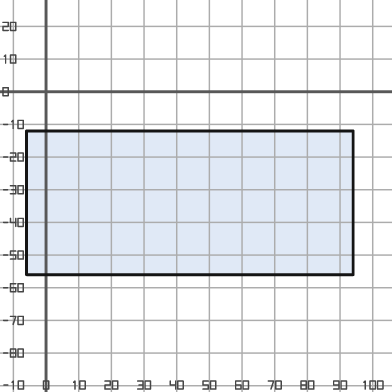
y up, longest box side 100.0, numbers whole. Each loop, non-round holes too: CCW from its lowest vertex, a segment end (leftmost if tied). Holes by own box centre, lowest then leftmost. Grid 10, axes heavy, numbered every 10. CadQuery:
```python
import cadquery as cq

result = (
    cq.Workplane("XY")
    .moveTo(-6.0, -56.0)
    .lineTo(94.0, -56.0)
    .lineTo(94.0, -12.0)
    .lineTo(-6.0, -12.0)
    .close()
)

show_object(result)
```